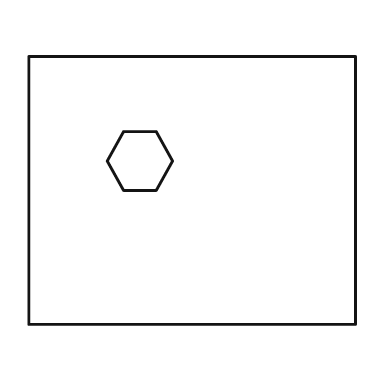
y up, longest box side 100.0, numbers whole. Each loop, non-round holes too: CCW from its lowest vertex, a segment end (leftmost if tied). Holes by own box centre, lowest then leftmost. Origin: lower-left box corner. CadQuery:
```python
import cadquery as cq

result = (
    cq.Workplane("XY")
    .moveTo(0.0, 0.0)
    .lineTo(100.0, 0.0)
    .lineTo(100.0, 82.0)
    .lineTo(0.0, 82.0)
    .close()
    .moveTo(29.0, 41.0)
    .lineTo(39.0, 41.0)
    .lineTo(44.0, 50.0)
    .lineTo(39.0, 59.0)
    .lineTo(29.0, 59.0)
    .lineTo(24.0, 50.0)
    .close()
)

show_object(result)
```